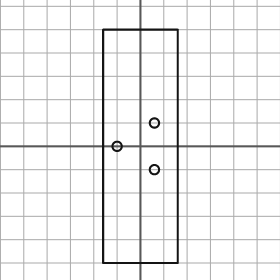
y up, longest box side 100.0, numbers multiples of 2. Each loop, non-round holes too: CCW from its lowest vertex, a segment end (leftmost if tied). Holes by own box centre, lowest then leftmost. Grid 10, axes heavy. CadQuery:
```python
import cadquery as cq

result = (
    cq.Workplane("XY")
    .moveTo(-16.0, -50.0)
    .lineTo(16.0, -50.0)
    .lineTo(16.0, 50.0)
    .lineTo(-16.0, 50.0)
    .close()
    .moveTo(6.0, -10.0)
    .circle(2.0)
    .moveTo(-10.0, 0.0)
    .circle(2.0)
    .moveTo(6.0, 10.0)
    .circle(2.0)
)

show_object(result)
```